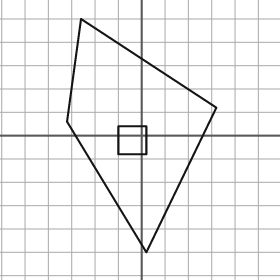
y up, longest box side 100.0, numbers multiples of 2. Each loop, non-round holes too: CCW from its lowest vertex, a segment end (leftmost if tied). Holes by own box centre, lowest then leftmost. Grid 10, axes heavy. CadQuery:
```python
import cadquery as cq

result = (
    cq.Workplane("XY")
    .moveTo(2.0, -50.0)
    .lineTo(32.0, 12.0)
    .lineTo(-26.0, 50.0)
    .lineTo(-32.0, 6.0)
    .close()
    .moveTo(-10.0, -8.0)
    .lineTo(2.0, -8.0)
    .lineTo(2.0, 4.0)
    .lineTo(-10.0, 4.0)
    .close()
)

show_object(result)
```